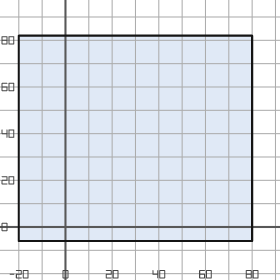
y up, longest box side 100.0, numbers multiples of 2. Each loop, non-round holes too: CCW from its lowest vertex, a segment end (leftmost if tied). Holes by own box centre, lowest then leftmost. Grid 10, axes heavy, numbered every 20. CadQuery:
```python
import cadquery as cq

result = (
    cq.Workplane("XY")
    .moveTo(-20.0, -6.0)
    .lineTo(80.0, -6.0)
    .lineTo(80.0, 82.0)
    .lineTo(-20.0, 82.0)
    .close()
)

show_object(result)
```